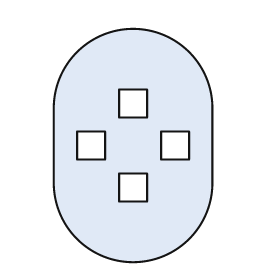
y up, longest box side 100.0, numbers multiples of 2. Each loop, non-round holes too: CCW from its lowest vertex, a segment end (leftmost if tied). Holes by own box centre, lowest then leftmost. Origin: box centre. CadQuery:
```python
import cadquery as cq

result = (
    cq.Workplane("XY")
    .moveTo(-34.0, -16.0)
    .threePointArc((0.0, -50.0), (34.0, -16.0))
    .lineTo(34.0, 16.0)
    .threePointArc((0.0, 50.0), (-34.0, 16.0))
    .close()
    .moveTo(-6.0, -24.0)
    .lineTo(6.0, -24.0)
    .lineTo(6.0, -12.0)
    .lineTo(-6.0, -12.0)
    .close()
    .moveTo(-24.0, -6.0)
    .lineTo(-12.0, -6.0)
    .lineTo(-12.0, 6.0)
    .lineTo(-24.0, 6.0)
    .close()
    .moveTo(12.0, -6.0)
    .lineTo(24.0, -6.0)
    .lineTo(24.0, 6.0)
    .lineTo(12.0, 6.0)
    .close()
    .moveTo(-6.0, 12.0)
    .lineTo(6.0, 12.0)
    .lineTo(6.0, 24.0)
    .lineTo(-6.0, 24.0)
    .close()
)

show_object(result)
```